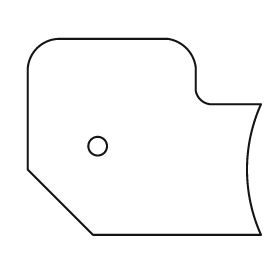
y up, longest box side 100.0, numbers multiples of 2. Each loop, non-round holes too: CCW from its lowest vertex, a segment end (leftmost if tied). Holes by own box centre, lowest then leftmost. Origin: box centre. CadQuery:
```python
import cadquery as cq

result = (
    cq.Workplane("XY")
    .moveTo(-22.0, -42.0)
    .lineTo(50.0, -42.0)
    .threePointArc((44.0, -14.0), (50.0, 14.0))
    .lineTo(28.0, 14.0)
    .threePointArc((24.0, 16.0), (22.0, 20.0))
    .lineTo(22.0, 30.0)
    .threePointArc((18.0, 38.0), (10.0, 42.0))
    .lineTo(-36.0, 42.0)
    .threePointArc((-46.0, 38.0), (-50.0, 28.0))
    .lineTo(-50.0, -14.0)
    .close()
    .moveTo(-20.0, -4.0)
    .circle(4.0)
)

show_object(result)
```